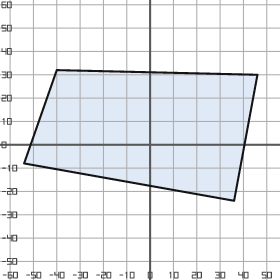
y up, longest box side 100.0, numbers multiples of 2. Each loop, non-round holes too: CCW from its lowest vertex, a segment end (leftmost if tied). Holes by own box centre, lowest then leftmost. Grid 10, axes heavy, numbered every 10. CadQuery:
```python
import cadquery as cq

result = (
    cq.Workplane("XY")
    .moveTo(36.0, -24.0)
    .lineTo(46.0, 30.0)
    .lineTo(-40.0, 32.0)
    .lineTo(-54.0, -8.0)
    .close()
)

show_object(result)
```